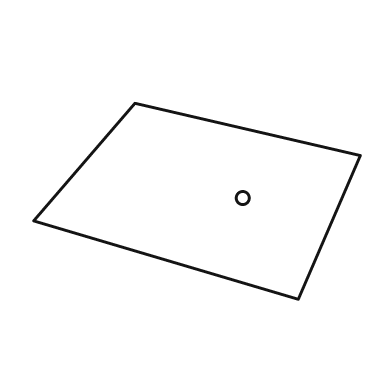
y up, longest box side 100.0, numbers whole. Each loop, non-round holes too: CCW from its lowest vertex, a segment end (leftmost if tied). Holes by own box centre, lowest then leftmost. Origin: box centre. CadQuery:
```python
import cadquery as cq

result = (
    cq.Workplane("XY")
    .moveTo(31.0, -30.0)
    .lineTo(50.0, 14.0)
    .lineTo(-19.0, 30.0)
    .lineTo(-50.0, -6.0)
    .close()
    .moveTo(14.0, 1.0)
    .circle(2.0)
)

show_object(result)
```